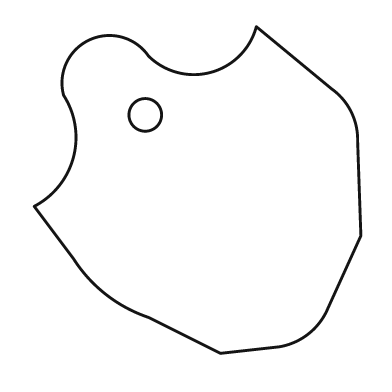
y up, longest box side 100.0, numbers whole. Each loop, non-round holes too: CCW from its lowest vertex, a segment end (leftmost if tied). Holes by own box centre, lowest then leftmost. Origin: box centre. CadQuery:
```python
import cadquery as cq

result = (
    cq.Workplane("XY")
    .moveTo(7.0, -50.0)
    .lineTo(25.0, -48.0)
    .threePointArc((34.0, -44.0), (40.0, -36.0))
    .lineTo(50.0, -14.0)
    .lineTo(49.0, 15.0)
    .threePointArc((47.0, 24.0), (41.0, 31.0))
    .lineTo(18.0, 50.0)
    .threePointArc((4.0, 36.0), (-15.0, 41.0))
    .threePointArc((-33.0, 46.0), (-41.0, 29.0))
    .threePointArc((-38.0, 10.0), (-50.0, -5.0))
    .lineTo(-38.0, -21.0)
    .threePointArc((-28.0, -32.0), (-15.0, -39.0))
    .close()
    .moveTo(-16.0, 23.0)
    .circle(5.0)
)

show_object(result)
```